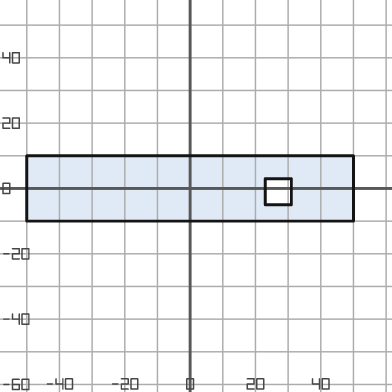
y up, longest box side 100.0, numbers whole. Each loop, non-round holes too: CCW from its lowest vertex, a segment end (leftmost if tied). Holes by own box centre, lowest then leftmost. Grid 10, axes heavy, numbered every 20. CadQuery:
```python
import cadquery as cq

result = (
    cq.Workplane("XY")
    .moveTo(-50.0, -10.0)
    .lineTo(50.0, -10.0)
    .lineTo(50.0, 10.0)
    .lineTo(-50.0, 10.0)
    .close()
    .moveTo(23.0, -5.0)
    .lineTo(31.0, -5.0)
    .lineTo(31.0, 3.0)
    .lineTo(23.0, 3.0)
    .close()
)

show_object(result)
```